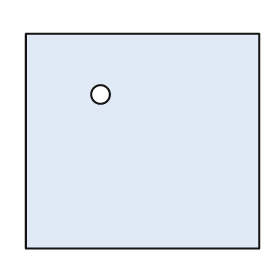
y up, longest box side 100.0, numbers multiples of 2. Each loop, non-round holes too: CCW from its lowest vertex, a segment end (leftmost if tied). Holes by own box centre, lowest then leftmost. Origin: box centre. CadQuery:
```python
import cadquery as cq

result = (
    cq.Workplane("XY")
    .moveTo(-50.0, -46.0)
    .lineTo(50.0, -46.0)
    .lineTo(50.0, 46.0)
    .lineTo(-50.0, 46.0)
    .close()
    .moveTo(-18.0, 20.0)
    .circle(4.0)
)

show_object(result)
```